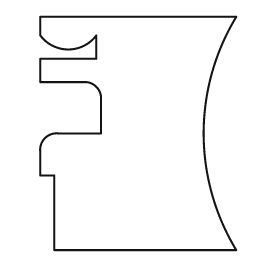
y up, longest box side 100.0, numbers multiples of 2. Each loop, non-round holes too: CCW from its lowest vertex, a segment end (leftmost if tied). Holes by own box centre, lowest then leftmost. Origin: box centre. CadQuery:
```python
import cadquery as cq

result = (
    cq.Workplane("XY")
    .moveTo(-36.0, -50.0)
    .lineTo(42.0, -50.0)
    .threePointArc((28.0, 0.0), (42.0, 50.0))
    .lineTo(-42.0, 50.0)
    .lineTo(-42.0, 42.0)
    .threePointArc((-30.0, 36.0), (-18.0, 42.0))
    .lineTo(-18.0, 32.0)
    .lineTo(-42.0, 32.0)
    .lineTo(-42.0, 22.0)
    .lineTo(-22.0, 22.0)
    .threePointArc((-18.0, 20.0), (-16.0, 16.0))
    .lineTo(-16.0, 0.0)
    .lineTo(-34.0, 0.0)
    .threePointArc((-40.0, -2.0), (-42.0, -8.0))
    .lineTo(-42.0, -18.0)
    .lineTo(-36.0, -18.0)
    .close()
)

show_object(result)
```